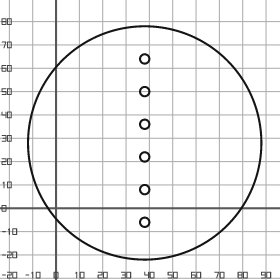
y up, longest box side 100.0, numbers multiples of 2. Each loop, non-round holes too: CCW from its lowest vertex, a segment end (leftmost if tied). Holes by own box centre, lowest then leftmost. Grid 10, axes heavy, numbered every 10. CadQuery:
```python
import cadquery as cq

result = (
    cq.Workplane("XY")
    .moveTo(38.0, 28.0)
    .circle(50.0)
    .moveTo(38.0, -6.0)
    .circle(2.0)
    .moveTo(38.0, 8.0)
    .circle(2.0)
    .moveTo(38.0, 22.0)
    .circle(2.0)
    .moveTo(38.0, 36.0)
    .circle(2.0)
    .moveTo(38.0, 50.0)
    .circle(2.0)
    .moveTo(38.0, 64.0)
    .circle(2.0)
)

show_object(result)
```